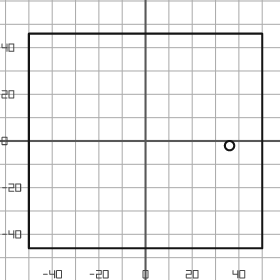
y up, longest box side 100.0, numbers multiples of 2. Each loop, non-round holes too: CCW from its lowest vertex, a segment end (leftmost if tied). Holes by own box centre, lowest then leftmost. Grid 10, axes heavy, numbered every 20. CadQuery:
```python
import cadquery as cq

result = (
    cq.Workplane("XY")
    .moveTo(-50.0, -46.0)
    .lineTo(50.0, -46.0)
    .lineTo(50.0, 46.0)
    .lineTo(-50.0, 46.0)
    .close()
    .moveTo(36.0, -2.0)
    .circle(2.0)
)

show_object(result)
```